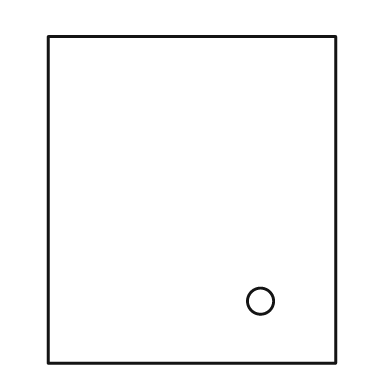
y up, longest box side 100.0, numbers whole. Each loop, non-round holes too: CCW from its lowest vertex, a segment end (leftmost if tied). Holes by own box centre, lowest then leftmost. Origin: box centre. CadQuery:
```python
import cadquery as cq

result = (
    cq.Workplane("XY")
    .moveTo(-44.0, -50.0)
    .lineTo(44.0, -50.0)
    .lineTo(44.0, 50.0)
    .lineTo(-44.0, 50.0)
    .close()
    .moveTo(21.0, -31.0)
    .circle(4.0)
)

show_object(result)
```